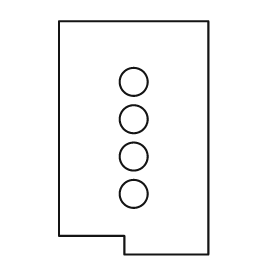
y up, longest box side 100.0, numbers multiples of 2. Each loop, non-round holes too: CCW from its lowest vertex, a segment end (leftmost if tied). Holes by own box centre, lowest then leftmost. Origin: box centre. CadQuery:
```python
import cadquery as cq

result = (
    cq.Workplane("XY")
    .moveTo(-4.0, -50.0)
    .lineTo(32.0, -50.0)
    .lineTo(32.0, 50.0)
    .lineTo(-32.0, 50.0)
    .lineTo(-32.0, -42.0)
    .lineTo(-4.0, -42.0)
    .close()
    .moveTo(0.0, -24.0)
    .circle(6.0)
    .moveTo(0.0, -8.0)
    .circle(6.0)
    .moveTo(0.0, 8.0)
    .circle(6.0)
    .moveTo(0.0, 24.0)
    .circle(6.0)
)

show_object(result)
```